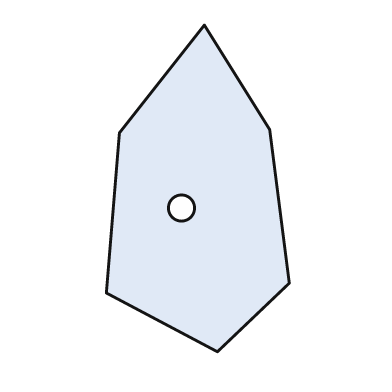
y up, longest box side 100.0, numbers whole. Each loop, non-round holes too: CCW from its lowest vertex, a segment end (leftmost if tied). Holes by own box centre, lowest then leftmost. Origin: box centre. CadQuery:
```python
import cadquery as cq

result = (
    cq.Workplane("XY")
    .moveTo(6.0, -50.0)
    .lineTo(28.0, -29.0)
    .lineTo(22.0, 18.0)
    .lineTo(2.0, 50.0)
    .lineTo(-24.0, 17.0)
    .lineTo(-28.0, -32.0)
    .close()
    .moveTo(-5.0, -6.0)
    .circle(4.0)
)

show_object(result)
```